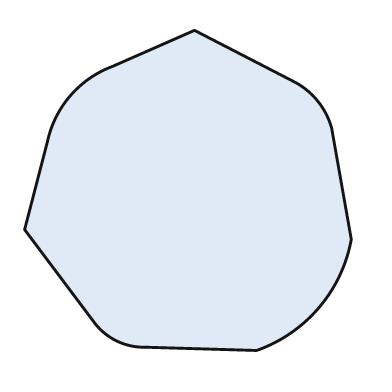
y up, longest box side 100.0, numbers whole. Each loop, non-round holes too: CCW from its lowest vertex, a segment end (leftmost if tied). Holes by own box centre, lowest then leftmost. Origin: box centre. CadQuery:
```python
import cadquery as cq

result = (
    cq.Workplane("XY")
    .moveTo(21.0, -49.0)
    .threePointArc((40.0, -36.0), (50.0, -15.0))
    .lineTo(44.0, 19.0)
    .threePointArc((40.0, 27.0), (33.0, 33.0))
    .lineTo(2.0, 49.0)
    .lineTo(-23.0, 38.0)
    .threePointArc((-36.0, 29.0), (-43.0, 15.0))
    .lineTo(-50.0, -12.0)
    .lineTo(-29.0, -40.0)
    .threePointArc((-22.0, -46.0), (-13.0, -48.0))
    .close()
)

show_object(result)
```